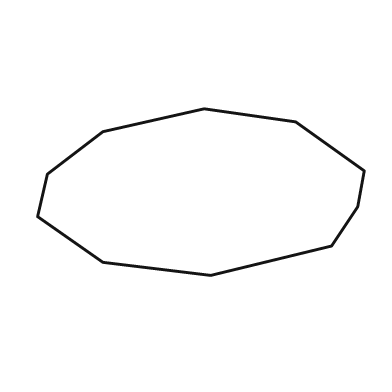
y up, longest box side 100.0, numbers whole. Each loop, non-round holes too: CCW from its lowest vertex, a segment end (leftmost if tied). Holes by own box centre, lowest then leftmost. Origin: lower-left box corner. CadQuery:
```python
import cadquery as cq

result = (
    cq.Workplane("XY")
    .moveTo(53.0, 0.0)
    .lineTo(90.0, 9.0)
    .lineTo(98.0, 21.0)
    .lineTo(100.0, 32.0)
    .lineTo(79.0, 47.0)
    .lineTo(51.0, 51.0)
    .lineTo(20.0, 44.0)
    .lineTo(3.0, 31.0)
    .lineTo(0.0, 18.0)
    .lineTo(20.0, 4.0)
    .close()
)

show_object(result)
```